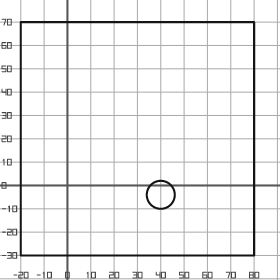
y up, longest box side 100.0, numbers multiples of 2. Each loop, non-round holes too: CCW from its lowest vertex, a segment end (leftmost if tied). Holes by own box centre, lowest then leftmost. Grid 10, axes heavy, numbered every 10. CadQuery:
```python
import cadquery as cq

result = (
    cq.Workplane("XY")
    .moveTo(-20.0, -30.0)
    .lineTo(80.0, -30.0)
    .lineTo(80.0, 70.0)
    .lineTo(-20.0, 70.0)
    .close()
    .moveTo(40.0, -4.0)
    .circle(6.0)
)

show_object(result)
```